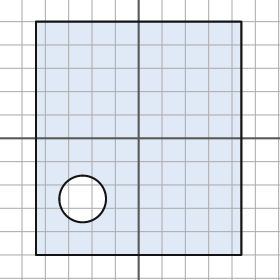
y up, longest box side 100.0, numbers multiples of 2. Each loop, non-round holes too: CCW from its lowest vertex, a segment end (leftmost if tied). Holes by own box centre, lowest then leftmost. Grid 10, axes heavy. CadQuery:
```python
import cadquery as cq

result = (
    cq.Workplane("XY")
    .moveTo(-44.0, -50.0)
    .lineTo(44.0, -50.0)
    .lineTo(44.0, 50.0)
    .lineTo(-44.0, 50.0)
    .close()
    .moveTo(-24.0, -26.0)
    .circle(10.0)
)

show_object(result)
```